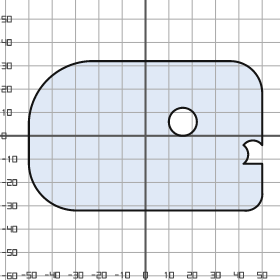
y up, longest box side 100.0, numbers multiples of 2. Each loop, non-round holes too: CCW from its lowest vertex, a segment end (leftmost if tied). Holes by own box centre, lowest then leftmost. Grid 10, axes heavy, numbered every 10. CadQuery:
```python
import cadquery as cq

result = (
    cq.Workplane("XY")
    .moveTo(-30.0, -32.0)
    .lineTo(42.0, -32.0)
    .threePointArc((48.0, -30.0), (50.0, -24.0))
    .lineTo(50.0, -12.0)
    .lineTo(42.0, -12.0)
    .threePointArc((44.0, -8.0), (42.0, -4.0))
    .threePointArc((46.0, -2.0), (50.0, -4.0))
    .lineTo(50.0, 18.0)
    .threePointArc((46.0, 28.0), (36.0, 32.0))
    .lineTo(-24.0, 32.0)
    .threePointArc((-42.0, 24.0), (-50.0, 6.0))
    .lineTo(-50.0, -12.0)
    .threePointArc((-44.0, -26.0), (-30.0, -32.0))
    .close()
    .moveTo(16.0, 6.0)
    .circle(6.0)
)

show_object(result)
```